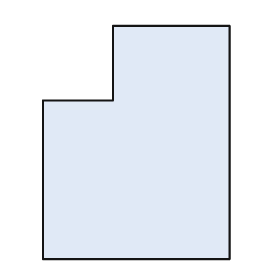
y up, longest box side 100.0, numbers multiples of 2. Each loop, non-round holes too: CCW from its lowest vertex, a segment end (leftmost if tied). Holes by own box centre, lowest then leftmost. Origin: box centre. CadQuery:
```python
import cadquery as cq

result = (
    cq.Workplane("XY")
    .moveTo(-40.0, -50.0)
    .lineTo(40.0, -50.0)
    .lineTo(40.0, 50.0)
    .lineTo(-10.0, 50.0)
    .lineTo(-10.0, 18.0)
    .lineTo(-40.0, 18.0)
    .close()
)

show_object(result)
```